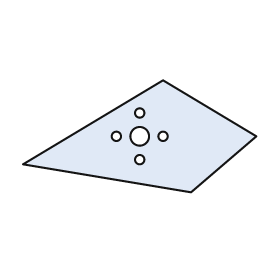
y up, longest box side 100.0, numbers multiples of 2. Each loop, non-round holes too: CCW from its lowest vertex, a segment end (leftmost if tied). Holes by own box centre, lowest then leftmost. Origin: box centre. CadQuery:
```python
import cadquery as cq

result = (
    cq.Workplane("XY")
    .moveTo(22.0, -24.0)
    .lineTo(50.0, 0.0)
    .lineTo(10.0, 24.0)
    .lineTo(-50.0, -12.0)
    .close()
    .moveTo(0.0, -10.0)
    .circle(2.0)
    .moveTo(-10.0, 0.0)
    .circle(2.0)
    .moveTo(0.0, 0.0)
    .circle(4.0)
    .moveTo(10.0, 0.0)
    .circle(2.0)
    .moveTo(0.0, 10.0)
    .circle(2.0)
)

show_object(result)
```